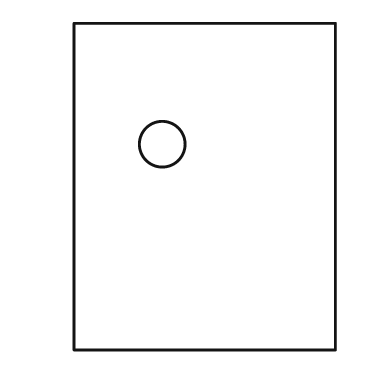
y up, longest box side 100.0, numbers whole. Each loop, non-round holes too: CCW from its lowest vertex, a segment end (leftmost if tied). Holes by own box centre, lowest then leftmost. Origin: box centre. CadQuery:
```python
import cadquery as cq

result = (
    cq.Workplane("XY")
    .moveTo(-40.0, -50.0)
    .lineTo(40.0, -50.0)
    .lineTo(40.0, 50.0)
    .lineTo(-40.0, 50.0)
    .close()
    .moveTo(-13.0, 13.0)
    .circle(7.0)
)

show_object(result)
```